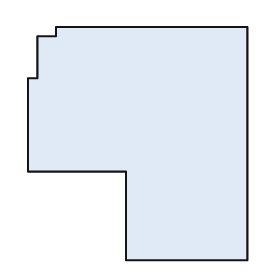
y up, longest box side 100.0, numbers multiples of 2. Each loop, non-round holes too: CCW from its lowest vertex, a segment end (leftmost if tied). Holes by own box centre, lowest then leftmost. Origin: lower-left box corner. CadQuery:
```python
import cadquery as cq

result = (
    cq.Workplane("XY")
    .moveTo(42.0, 0.0)
    .lineTo(94.0, 0.0)
    .lineTo(94.0, 100.0)
    .lineTo(12.0, 100.0)
    .lineTo(12.0, 96.0)
    .lineTo(4.0, 96.0)
    .lineTo(4.0, 78.0)
    .lineTo(0.0, 78.0)
    .lineTo(0.0, 38.0)
    .lineTo(42.0, 38.0)
    .close()
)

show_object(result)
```